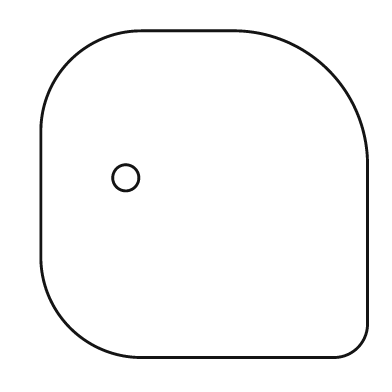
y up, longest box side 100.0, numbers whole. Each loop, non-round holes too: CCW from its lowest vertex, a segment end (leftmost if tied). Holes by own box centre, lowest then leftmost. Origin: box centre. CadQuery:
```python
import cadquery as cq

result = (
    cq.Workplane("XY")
    .moveTo(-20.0, -50.0)
    .lineTo(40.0, -50.0)
    .threePointArc((47.0, -47.0), (50.0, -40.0))
    .lineTo(50.0, 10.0)
    .threePointArc((38.0, 38.0), (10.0, 50.0))
    .lineTo(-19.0, 50.0)
    .threePointArc((-41.0, 41.0), (-50.0, 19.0))
    .lineTo(-50.0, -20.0)
    .threePointArc((-41.0, -41.0), (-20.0, -50.0))
    .close()
    .moveTo(-24.0, 5.0)
    .circle(4.0)
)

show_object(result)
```